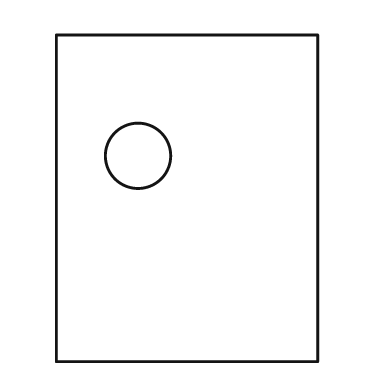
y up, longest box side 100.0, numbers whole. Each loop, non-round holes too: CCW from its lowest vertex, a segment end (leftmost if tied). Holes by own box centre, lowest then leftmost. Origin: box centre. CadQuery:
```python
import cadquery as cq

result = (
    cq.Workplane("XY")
    .moveTo(-40.0, -50.0)
    .lineTo(40.0, -50.0)
    .lineTo(40.0, 50.0)
    .lineTo(-40.0, 50.0)
    .close()
    .moveTo(-15.0, 13.0)
    .circle(10.0)
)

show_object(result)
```